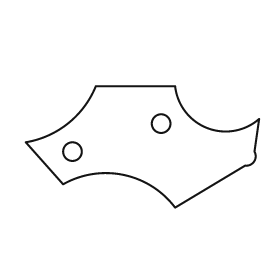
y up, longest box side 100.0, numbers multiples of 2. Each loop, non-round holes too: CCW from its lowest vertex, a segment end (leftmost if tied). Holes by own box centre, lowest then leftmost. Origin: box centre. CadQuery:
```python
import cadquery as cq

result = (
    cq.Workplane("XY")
    .moveTo(14.0, -26.0)
    .lineTo(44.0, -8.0)
    .threePointArc((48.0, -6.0), (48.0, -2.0))
    .lineTo(50.0, 12.0)
    .threePointArc((28.0, 8.0), (14.0, 26.0))
    .lineTo(-20.0, 26.0)
    .threePointArc((-32.0, 10.0), (-50.0, 2.0))
    .lineTo(-34.0, -16.0)
    .threePointArc((-8.0, -12.0), (14.0, -26.0))
    .close()
    .moveTo(-30.0, -2.0)
    .circle(4.0)
    .moveTo(8.0, 10.0)
    .circle(4.0)
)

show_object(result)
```